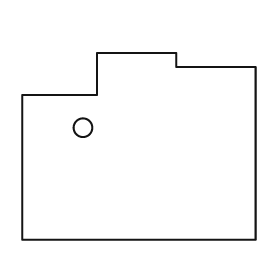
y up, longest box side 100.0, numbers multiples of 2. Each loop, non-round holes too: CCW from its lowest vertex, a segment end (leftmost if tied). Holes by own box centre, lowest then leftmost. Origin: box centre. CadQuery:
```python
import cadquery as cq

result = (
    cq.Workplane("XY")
    .moveTo(-50.0, -40.0)
    .lineTo(50.0, -40.0)
    .lineTo(50.0, 34.0)
    .lineTo(16.0, 34.0)
    .lineTo(16.0, 40.0)
    .lineTo(-18.0, 40.0)
    .lineTo(-18.0, 22.0)
    .lineTo(-50.0, 22.0)
    .close()
    .moveTo(-24.0, 8.0)
    .circle(4.0)
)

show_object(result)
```